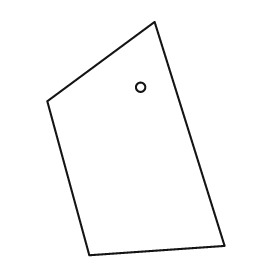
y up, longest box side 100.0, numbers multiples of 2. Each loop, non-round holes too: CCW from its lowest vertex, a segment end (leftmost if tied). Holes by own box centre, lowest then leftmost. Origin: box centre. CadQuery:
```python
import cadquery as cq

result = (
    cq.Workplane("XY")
    .moveTo(-20.0, -50.0)
    .lineTo(38.0, -46.0)
    .lineTo(8.0, 50.0)
    .lineTo(-38.0, 16.0)
    .close()
    .moveTo(2.0, 22.0)
    .circle(2.0)
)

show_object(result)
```